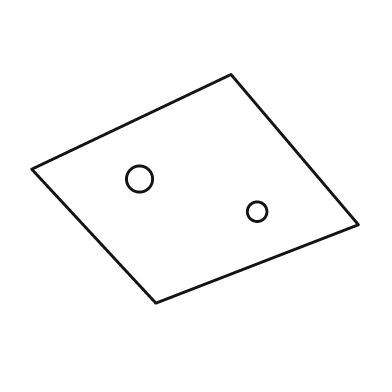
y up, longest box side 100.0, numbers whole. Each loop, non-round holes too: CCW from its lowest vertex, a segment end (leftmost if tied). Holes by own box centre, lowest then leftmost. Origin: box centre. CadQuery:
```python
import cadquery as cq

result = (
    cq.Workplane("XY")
    .moveTo(-12.0, -35.0)
    .lineTo(50.0, -11.0)
    .lineTo(11.0, 35.0)
    .lineTo(-50.0, 6.0)
    .close()
    .moveTo(19.0, -7.0)
    .circle(3.0)
    .moveTo(-17.0, 3.0)
    .circle(4.0)
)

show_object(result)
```